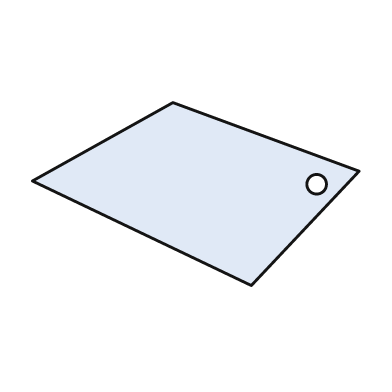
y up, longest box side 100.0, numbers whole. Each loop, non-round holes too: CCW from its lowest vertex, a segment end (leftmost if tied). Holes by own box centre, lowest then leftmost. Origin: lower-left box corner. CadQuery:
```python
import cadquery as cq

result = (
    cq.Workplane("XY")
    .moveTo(67.0, 0.0)
    .lineTo(100.0, 35.0)
    .lineTo(43.0, 56.0)
    .lineTo(0.0, 32.0)
    .close()
    .moveTo(87.0, 31.0)
    .circle(3.0)
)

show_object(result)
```